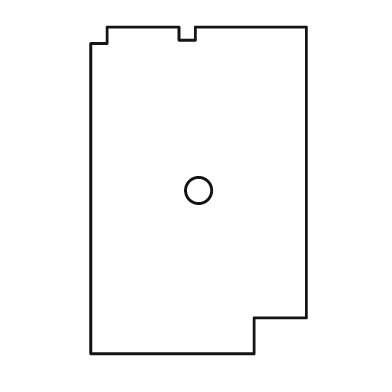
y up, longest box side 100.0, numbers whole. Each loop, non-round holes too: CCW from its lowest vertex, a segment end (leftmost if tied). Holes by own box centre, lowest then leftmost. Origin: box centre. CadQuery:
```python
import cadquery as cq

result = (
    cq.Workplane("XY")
    .moveTo(-33.0, -50.0)
    .lineTo(17.0, -50.0)
    .lineTo(17.0, -39.0)
    .lineTo(33.0, -39.0)
    .lineTo(33.0, 50.0)
    .lineTo(-1.0, 50.0)
    .lineTo(-1.0, 46.0)
    .lineTo(-6.0, 46.0)
    .lineTo(-6.0, 50.0)
    .lineTo(-28.0, 50.0)
    .lineTo(-28.0, 45.0)
    .lineTo(-33.0, 45.0)
    .close()
    .moveTo(0.0, 0.0)
    .circle(4.0)
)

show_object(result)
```